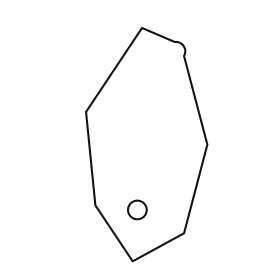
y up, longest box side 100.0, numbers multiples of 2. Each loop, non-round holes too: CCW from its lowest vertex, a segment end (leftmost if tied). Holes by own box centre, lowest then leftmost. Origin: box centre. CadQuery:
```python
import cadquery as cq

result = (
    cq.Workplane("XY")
    .moveTo(-6.0, -50.0)
    .lineTo(16.0, -38.0)
    .lineTo(26.0, 0.0)
    .lineTo(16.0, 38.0)
    .threePointArc((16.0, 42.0), (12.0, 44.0))
    .lineTo(-2.0, 50.0)
    .lineTo(-26.0, 14.0)
    .lineTo(-22.0, -26.0)
    .close()
    .moveTo(-4.0, -28.0)
    .circle(4.0)
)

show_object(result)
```